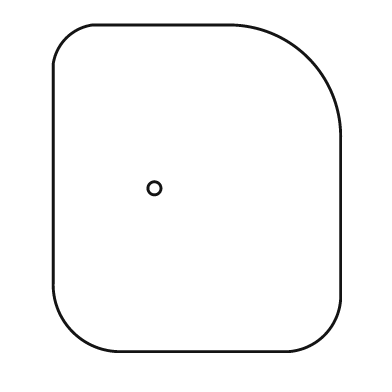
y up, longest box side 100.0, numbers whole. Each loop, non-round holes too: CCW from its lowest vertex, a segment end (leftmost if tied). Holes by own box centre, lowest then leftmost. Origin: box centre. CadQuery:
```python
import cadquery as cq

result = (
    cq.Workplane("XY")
    .moveTo(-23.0, -50.0)
    .lineTo(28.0, -50.0)
    .threePointArc((39.0, -45.0), (44.0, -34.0))
    .lineTo(44.0, 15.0)
    .threePointArc((34.0, 40.0), (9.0, 50.0))
    .lineTo(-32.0, 50.0)
    .threePointArc((-40.0, 46.0), (-44.0, 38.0))
    .lineTo(-44.0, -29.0)
    .threePointArc((-38.0, -44.0), (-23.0, -50.0))
    .close()
    .moveTo(-13.0, 0.0)
    .circle(2.0)
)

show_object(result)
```